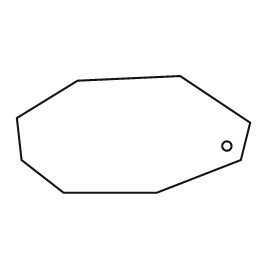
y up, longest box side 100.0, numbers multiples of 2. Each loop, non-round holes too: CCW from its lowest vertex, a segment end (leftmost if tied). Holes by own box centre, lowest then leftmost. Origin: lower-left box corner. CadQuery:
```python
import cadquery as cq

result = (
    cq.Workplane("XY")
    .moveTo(20.0, 0.0)
    .lineTo(60.0, 0.0)
    .lineTo(96.0, 14.0)
    .lineTo(100.0, 30.0)
    .lineTo(70.0, 50.0)
    .lineTo(26.0, 48.0)
    .lineTo(0.0, 32.0)
    .lineTo(2.0, 14.0)
    .close()
    .moveTo(90.0, 20.0)
    .circle(2.0)
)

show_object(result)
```